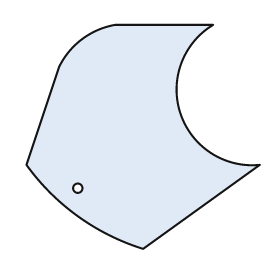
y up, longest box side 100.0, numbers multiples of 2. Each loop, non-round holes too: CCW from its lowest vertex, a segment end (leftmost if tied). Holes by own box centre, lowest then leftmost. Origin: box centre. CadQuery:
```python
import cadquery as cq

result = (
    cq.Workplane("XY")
    .moveTo(0.0, -48.0)
    .lineTo(50.0, -12.0)
    .threePointArc((16.0, 10.0), (30.0, 48.0))
    .lineTo(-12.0, 48.0)
    .threePointArc((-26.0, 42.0), (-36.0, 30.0))
    .lineTo(-50.0, -12.0)
    .threePointArc((-28.0, -34.0), (0.0, -48.0))
    .close()
    .moveTo(-28.0, -22.0)
    .circle(2.0)
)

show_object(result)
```